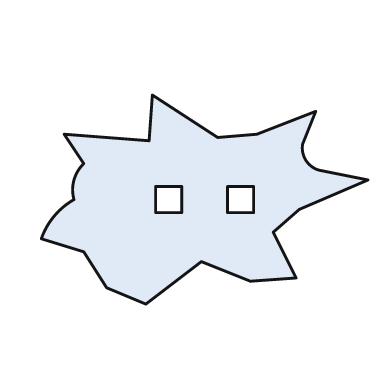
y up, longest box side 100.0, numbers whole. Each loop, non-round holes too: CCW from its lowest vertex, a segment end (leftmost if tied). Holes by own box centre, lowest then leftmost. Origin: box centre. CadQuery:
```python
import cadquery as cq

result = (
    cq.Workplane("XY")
    .moveTo(-18.0, -32.0)
    .lineTo(-1.0, -19.0)
    .lineTo(14.0, -25.0)
    .lineTo(28.0, -24.0)
    .lineTo(21.0, -10.0)
    .lineTo(29.0, -3.0)
    .lineTo(50.0, 6.0)
    .lineTo(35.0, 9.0)
    .threePointArc((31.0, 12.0), (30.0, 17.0))
    .lineTo(34.0, 27.0)
    .lineTo(16.0, 20.0)
    .lineTo(4.0, 19.0)
    .lineTo(-16.0, 32.0)
    .lineTo(-17.0, 18.0)
    .lineTo(-43.0, 20.0)
    .lineTo(-37.0, 11.0)
    .threePointArc((-40.0, 6.0), (-40.0, 0.0))
    .threePointArc((-46.0, -5.0), (-50.0, -12.0))
    .lineTo(-37.0, -16.0)
    .lineTo(-30.0, -27.0)
    .close()
    .moveTo(-15.0, -4.0)
    .lineTo(-7.0, -4.0)
    .lineTo(-7.0, 4.0)
    .lineTo(-15.0, 4.0)
    .close()
    .moveTo(7.0, -4.0)
    .lineTo(15.0, -4.0)
    .lineTo(15.0, 4.0)
    .lineTo(7.0, 4.0)
    .close()
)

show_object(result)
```